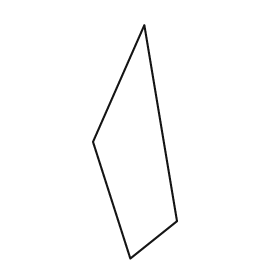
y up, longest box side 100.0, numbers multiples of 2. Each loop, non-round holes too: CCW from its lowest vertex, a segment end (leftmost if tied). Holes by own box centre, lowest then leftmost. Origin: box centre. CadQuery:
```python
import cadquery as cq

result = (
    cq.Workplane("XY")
    .moveTo(-2.0, -50.0)
    .lineTo(18.0, -34.0)
    .lineTo(4.0, 50.0)
    .lineTo(-18.0, 0.0)
    .close()
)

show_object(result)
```